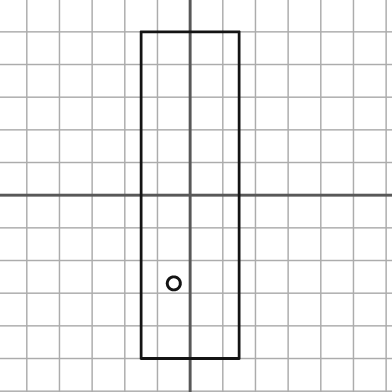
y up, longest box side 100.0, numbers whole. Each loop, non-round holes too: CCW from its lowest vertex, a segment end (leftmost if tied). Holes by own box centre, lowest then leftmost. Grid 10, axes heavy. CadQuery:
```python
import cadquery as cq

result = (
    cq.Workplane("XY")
    .moveTo(-15.0, -50.0)
    .lineTo(15.0, -50.0)
    .lineTo(15.0, 50.0)
    .lineTo(-15.0, 50.0)
    .close()
    .moveTo(-5.0, -27.0)
    .circle(2.0)
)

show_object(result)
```